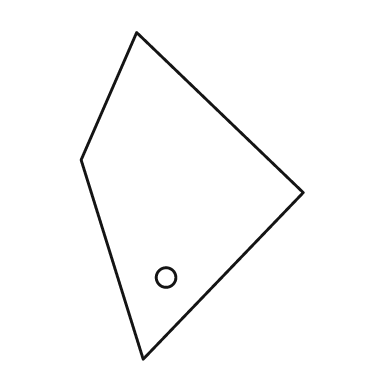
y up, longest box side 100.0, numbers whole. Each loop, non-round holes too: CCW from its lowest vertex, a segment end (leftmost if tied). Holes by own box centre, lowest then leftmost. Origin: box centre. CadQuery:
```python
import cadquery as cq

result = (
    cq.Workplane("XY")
    .moveTo(-15.0, -50.0)
    .lineTo(34.0, 1.0)
    .lineTo(-17.0, 50.0)
    .lineTo(-34.0, 11.0)
    .close()
    .moveTo(-8.0, -25.0)
    .circle(3.0)
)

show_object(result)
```